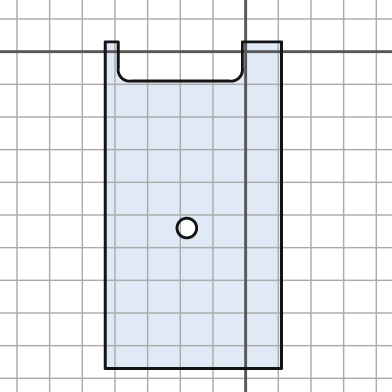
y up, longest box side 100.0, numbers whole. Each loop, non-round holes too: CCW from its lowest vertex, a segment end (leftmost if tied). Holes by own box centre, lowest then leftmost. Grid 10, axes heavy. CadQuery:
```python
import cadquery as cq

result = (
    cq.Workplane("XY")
    .moveTo(-43.0, -97.0)
    .lineTo(11.0, -97.0)
    .lineTo(11.0, 3.0)
    .lineTo(-1.0, 3.0)
    .lineTo(-1.0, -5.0)
    .threePointArc((-2.0, -8.0), (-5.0, -9.0))
    .lineTo(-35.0, -9.0)
    .threePointArc((-38.0, -8.0), (-39.0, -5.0))
    .lineTo(-39.0, 3.0)
    .lineTo(-43.0, 3.0)
    .close()
    .moveTo(-18.0, -54.0)
    .circle(3.0)
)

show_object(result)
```